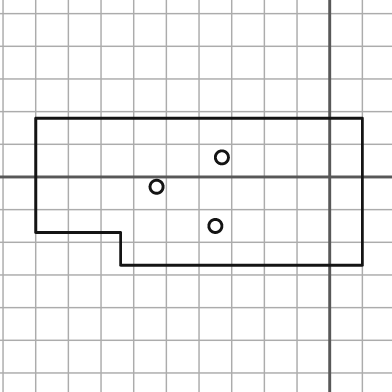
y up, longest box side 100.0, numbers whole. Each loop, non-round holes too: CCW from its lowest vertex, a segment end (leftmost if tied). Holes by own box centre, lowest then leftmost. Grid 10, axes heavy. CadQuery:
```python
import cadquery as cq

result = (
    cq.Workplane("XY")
    .moveTo(-64.0, -27.0)
    .lineTo(10.0, -27.0)
    .lineTo(10.0, 18.0)
    .lineTo(-90.0, 18.0)
    .lineTo(-90.0, -17.0)
    .lineTo(-64.0, -17.0)
    .close()
    .moveTo(-35.0, -15.0)
    .circle(2.0)
    .moveTo(-53.0, -3.0)
    .circle(2.0)
    .moveTo(-33.0, 6.0)
    .circle(2.0)
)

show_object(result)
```